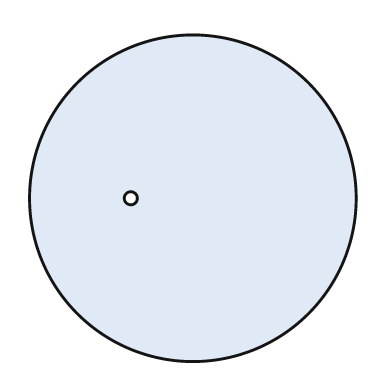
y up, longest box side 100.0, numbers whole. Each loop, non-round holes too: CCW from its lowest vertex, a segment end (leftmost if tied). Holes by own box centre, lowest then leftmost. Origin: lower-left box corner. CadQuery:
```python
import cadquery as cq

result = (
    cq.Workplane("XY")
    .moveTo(50.0, 50.0)
    .circle(50.0)
    .moveTo(31.0, 50.0)
    .circle(2.0)
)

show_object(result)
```